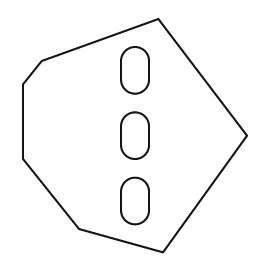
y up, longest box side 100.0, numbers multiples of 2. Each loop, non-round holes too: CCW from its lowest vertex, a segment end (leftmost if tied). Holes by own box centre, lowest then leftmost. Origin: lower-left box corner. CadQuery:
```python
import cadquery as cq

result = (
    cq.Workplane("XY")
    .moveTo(60.0, 0.0)
    .lineTo(96.0, 50.0)
    .lineTo(58.0, 100.0)
    .lineTo(8.0, 82.0)
    .lineTo(0.0, 72.0)
    .lineTo(0.0, 40.0)
    .lineTo(24.0, 10.0)
    .close()
    .moveTo(42.0, 18.0)
    .threePointArc((48.0, 12.0), (54.0, 18.0))
    .lineTo(54.0, 26.0)
    .threePointArc((48.0, 32.0), (42.0, 26.0))
    .close()
    .moveTo(42.0, 46.0)
    .threePointArc((48.0, 40.0), (54.0, 46.0))
    .lineTo(54.0, 54.0)
    .threePointArc((48.0, 60.0), (42.0, 54.0))
    .close()
    .moveTo(42.0, 74.0)
    .threePointArc((48.0, 68.0), (54.0, 74.0))
    .lineTo(54.0, 82.0)
    .threePointArc((48.0, 88.0), (42.0, 82.0))
    .close()
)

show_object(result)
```